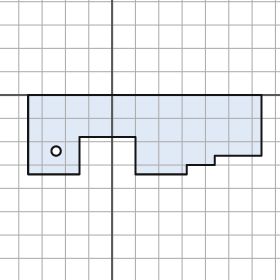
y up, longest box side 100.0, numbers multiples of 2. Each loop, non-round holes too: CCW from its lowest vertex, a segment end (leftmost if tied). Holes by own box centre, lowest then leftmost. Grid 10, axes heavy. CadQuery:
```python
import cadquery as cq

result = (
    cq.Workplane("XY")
    .moveTo(-36.0, -34.0)
    .lineTo(-14.0, -34.0)
    .lineTo(-14.0, -18.0)
    .lineTo(10.0, -18.0)
    .lineTo(10.0, -34.0)
    .lineTo(32.0, -34.0)
    .lineTo(32.0, -30.0)
    .lineTo(44.0, -30.0)
    .lineTo(44.0, -26.0)
    .lineTo(64.0, -26.0)
    .lineTo(64.0, 0.0)
    .lineTo(-36.0, 0.0)
    .close()
    .moveTo(-24.0, -24.0)
    .circle(2.0)
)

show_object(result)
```